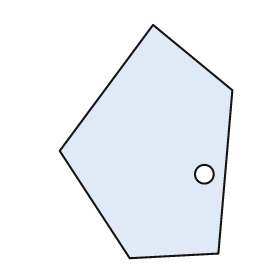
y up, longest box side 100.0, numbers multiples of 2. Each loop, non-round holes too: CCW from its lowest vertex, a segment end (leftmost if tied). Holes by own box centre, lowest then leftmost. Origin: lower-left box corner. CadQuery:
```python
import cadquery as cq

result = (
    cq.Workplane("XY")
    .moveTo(30.0, 0.0)
    .lineTo(68.0, 2.0)
    .lineTo(74.0, 72.0)
    .lineTo(40.0, 100.0)
    .lineTo(0.0, 46.0)
    .close()
    .moveTo(62.0, 36.0)
    .circle(4.0)
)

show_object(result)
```